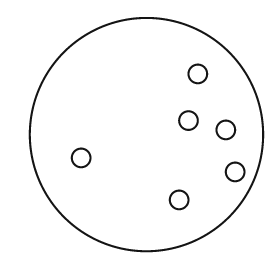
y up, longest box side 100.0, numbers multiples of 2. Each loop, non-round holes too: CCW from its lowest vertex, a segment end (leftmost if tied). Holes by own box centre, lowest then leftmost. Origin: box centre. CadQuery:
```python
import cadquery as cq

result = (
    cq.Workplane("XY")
    .moveTo(0.0, 0.0)
    .circle(50.0)
    .moveTo(14.0, -28.0)
    .circle(4.0)
    .moveTo(38.0, -16.0)
    .circle(4.0)
    .moveTo(-28.0, -10.0)
    .circle(4.0)
    .moveTo(34.0, 2.0)
    .circle(4.0)
    .moveTo(18.0, 6.0)
    .circle(4.0)
    .moveTo(22.0, 26.0)
    .circle(4.0)
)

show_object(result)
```